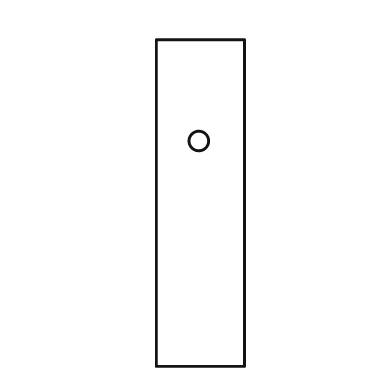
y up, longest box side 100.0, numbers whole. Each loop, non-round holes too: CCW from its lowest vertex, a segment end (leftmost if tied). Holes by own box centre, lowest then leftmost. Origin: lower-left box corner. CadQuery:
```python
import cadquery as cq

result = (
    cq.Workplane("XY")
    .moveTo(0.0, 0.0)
    .lineTo(27.0, 0.0)
    .lineTo(27.0, 100.0)
    .lineTo(0.0, 100.0)
    .close()
    .moveTo(13.0, 69.0)
    .circle(3.0)
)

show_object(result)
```